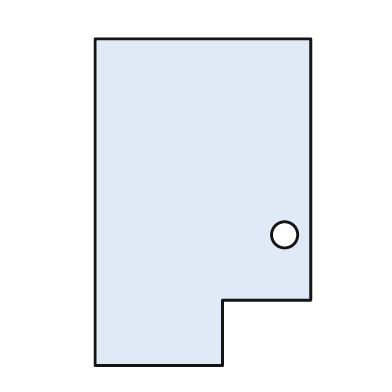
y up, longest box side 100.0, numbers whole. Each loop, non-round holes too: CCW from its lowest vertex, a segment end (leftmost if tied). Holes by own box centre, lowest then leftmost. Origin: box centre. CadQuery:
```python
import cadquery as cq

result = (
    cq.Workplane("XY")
    .moveTo(-33.0, -50.0)
    .lineTo(6.0, -50.0)
    .lineTo(6.0, -30.0)
    .lineTo(33.0, -30.0)
    .lineTo(33.0, 50.0)
    .lineTo(-33.0, 50.0)
    .close()
    .moveTo(25.0, -10.0)
    .circle(4.0)
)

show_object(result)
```